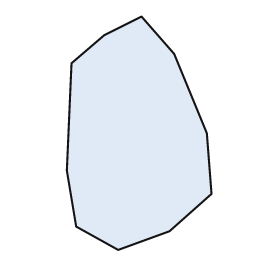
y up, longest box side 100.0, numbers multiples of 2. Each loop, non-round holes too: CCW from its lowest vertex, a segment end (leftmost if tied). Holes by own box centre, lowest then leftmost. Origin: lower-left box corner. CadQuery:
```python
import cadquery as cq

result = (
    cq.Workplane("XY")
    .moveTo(22.0, 0.0)
    .lineTo(44.0, 8.0)
    .lineTo(62.0, 24.0)
    .lineTo(60.0, 50.0)
    .lineTo(46.0, 84.0)
    .lineTo(32.0, 100.0)
    .lineTo(16.0, 92.0)
    .lineTo(2.0, 80.0)
    .lineTo(0.0, 34.0)
    .lineTo(4.0, 10.0)
    .close()
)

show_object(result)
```